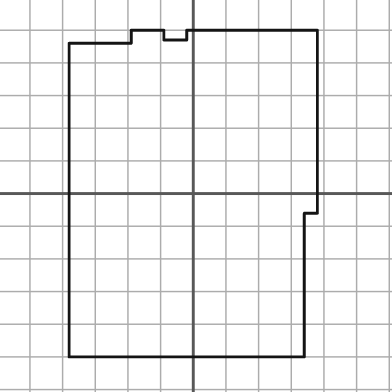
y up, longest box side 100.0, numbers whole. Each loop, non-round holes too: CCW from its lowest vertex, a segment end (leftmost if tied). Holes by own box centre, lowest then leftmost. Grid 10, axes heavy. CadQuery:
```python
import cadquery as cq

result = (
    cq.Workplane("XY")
    .moveTo(-38.0, -50.0)
    .lineTo(34.0, -50.0)
    .lineTo(34.0, -6.0)
    .lineTo(38.0, -6.0)
    .lineTo(38.0, 50.0)
    .lineTo(-2.0, 50.0)
    .lineTo(-2.0, 47.0)
    .lineTo(-9.0, 47.0)
    .lineTo(-9.0, 50.0)
    .lineTo(-19.0, 50.0)
    .lineTo(-19.0, 46.0)
    .lineTo(-38.0, 46.0)
    .close()
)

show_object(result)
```